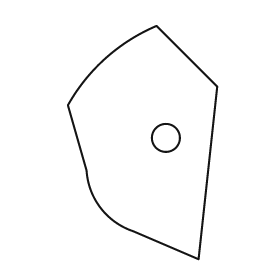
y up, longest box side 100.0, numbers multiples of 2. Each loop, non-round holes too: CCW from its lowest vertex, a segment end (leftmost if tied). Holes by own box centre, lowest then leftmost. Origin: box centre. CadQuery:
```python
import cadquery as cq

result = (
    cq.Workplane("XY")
    .moveTo(24.0, -50.0)
    .lineTo(32.0, 24.0)
    .lineTo(6.0, 50.0)
    .threePointArc((-16.0, 36.0), (-32.0, 16.0))
    .lineTo(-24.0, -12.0)
    .threePointArc((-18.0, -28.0), (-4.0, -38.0))
    .close()
    .moveTo(10.0, 2.0)
    .circle(6.0)
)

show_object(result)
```